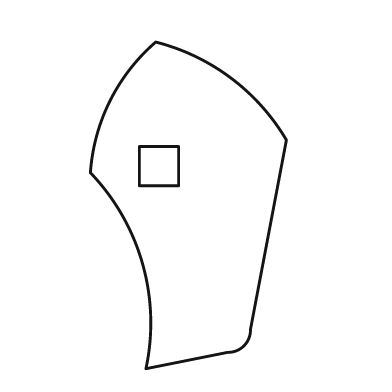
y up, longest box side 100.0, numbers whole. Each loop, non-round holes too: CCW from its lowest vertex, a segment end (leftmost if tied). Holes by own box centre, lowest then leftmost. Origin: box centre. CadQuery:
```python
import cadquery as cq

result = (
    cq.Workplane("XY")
    .moveTo(-13.0, -50.0)
    .lineTo(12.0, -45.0)
    .threePointArc((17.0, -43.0), (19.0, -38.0))
    .lineTo(30.0, 20.0)
    .threePointArc((13.0, 39.0), (-10.0, 50.0))
    .threePointArc((-24.0, 32.0), (-30.0, 10.0))
    .threePointArc((-14.0, -18.0), (-13.0, -50.0))
    .close()
    .moveTo(-15.0, 6.0)
    .lineTo(-3.0, 6.0)
    .lineTo(-3.0, 18.0)
    .lineTo(-15.0, 18.0)
    .close()
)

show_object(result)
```